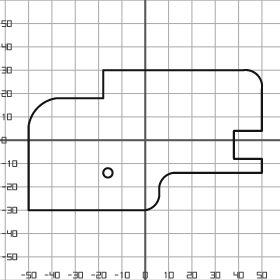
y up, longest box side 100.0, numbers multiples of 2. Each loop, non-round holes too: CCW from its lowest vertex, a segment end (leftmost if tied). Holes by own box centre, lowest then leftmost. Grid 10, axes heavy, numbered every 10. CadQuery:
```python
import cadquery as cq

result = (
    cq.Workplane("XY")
    .moveTo(-50.0, -30.0)
    .lineTo(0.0, -30.0)
    .threePointArc((4.0, -28.0), (6.0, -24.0))
    .lineTo(6.0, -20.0)
    .threePointArc((8.0, -16.0), (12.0, -14.0))
    .lineTo(50.0, -14.0)
    .lineTo(50.0, -8.0)
    .lineTo(38.0, -8.0)
    .lineTo(38.0, 4.0)
    .lineTo(50.0, 4.0)
    .lineTo(50.0, 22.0)
    .threePointArc((48.0, 28.0), (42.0, 30.0))
    .lineTo(-18.0, 30.0)
    .lineTo(-18.0, 18.0)
    .lineTo(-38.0, 18.0)
    .threePointArc((-46.0, 14.0), (-50.0, 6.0))
    .close()
    .moveTo(-16.0, -14.0)
    .circle(2.0)
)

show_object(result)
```